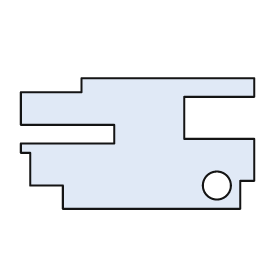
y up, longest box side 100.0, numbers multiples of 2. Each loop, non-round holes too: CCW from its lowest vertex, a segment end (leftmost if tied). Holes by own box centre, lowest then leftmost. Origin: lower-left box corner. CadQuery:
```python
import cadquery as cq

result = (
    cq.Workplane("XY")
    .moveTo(18.0, 0.0)
    .lineTo(94.0, 0.0)
    .lineTo(94.0, 12.0)
    .lineTo(100.0, 12.0)
    .lineTo(100.0, 30.0)
    .lineTo(70.0, 30.0)
    .lineTo(70.0, 48.0)
    .lineTo(100.0, 48.0)
    .lineTo(100.0, 56.0)
    .lineTo(26.0, 56.0)
    .lineTo(26.0, 50.0)
    .lineTo(0.0, 50.0)
    .lineTo(0.0, 36.0)
    .lineTo(40.0, 36.0)
    .lineTo(40.0, 28.0)
    .lineTo(0.0, 28.0)
    .lineTo(0.0, 24.0)
    .lineTo(4.0, 24.0)
    .lineTo(4.0, 10.0)
    .lineTo(18.0, 10.0)
    .close()
    .moveTo(84.0, 10.0)
    .circle(6.0)
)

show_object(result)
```